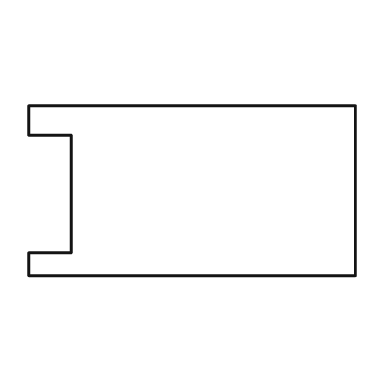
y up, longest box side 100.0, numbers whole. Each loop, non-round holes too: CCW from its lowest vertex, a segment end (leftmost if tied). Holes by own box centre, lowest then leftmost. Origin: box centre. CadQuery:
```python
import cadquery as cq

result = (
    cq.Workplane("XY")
    .moveTo(-50.0, -26.0)
    .lineTo(50.0, -26.0)
    .lineTo(50.0, 26.0)
    .lineTo(-50.0, 26.0)
    .lineTo(-50.0, 17.0)
    .lineTo(-37.0, 17.0)
    .lineTo(-37.0, -19.0)
    .lineTo(-50.0, -19.0)
    .close()
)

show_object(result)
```